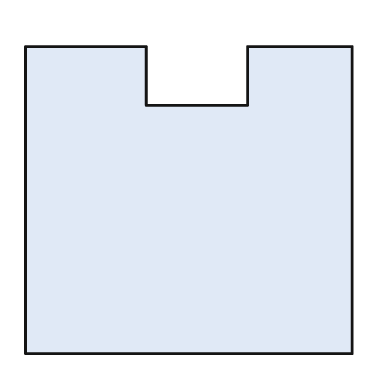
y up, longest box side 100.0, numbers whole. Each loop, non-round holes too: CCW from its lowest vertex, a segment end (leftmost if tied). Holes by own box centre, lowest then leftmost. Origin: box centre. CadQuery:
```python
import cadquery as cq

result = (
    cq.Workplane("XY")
    .moveTo(-50.0, -47.0)
    .lineTo(50.0, -47.0)
    .lineTo(50.0, 47.0)
    .lineTo(18.0, 47.0)
    .lineTo(18.0, 29.0)
    .lineTo(-13.0, 29.0)
    .lineTo(-13.0, 47.0)
    .lineTo(-50.0, 47.0)
    .close()
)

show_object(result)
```